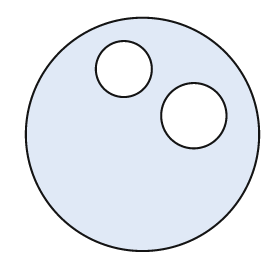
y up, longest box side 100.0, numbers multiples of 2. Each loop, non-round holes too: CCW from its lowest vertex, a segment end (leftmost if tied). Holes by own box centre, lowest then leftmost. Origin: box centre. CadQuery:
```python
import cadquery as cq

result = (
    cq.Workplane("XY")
    .moveTo(0.0, 0.0)
    .circle(50.0)
    .moveTo(22.0, 8.0)
    .circle(14.0)
    .moveTo(-8.0, 28.0)
    .circle(12.0)
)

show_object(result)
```